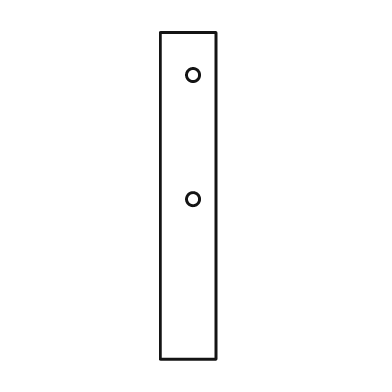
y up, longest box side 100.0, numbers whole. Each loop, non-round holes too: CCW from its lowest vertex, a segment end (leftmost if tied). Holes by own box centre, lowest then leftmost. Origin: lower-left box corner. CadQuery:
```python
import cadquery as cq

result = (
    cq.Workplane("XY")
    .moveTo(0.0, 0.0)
    .lineTo(17.0, 0.0)
    .lineTo(17.0, 100.0)
    .lineTo(0.0, 100.0)
    .close()
    .moveTo(10.0, 49.0)
    .circle(2.0)
    .moveTo(10.0, 87.0)
    .circle(2.0)
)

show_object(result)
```